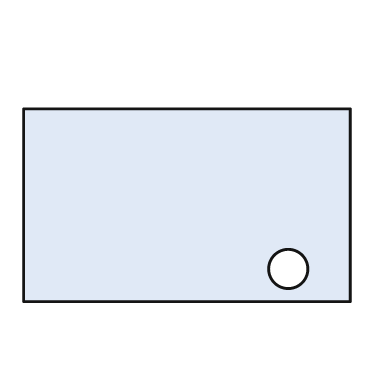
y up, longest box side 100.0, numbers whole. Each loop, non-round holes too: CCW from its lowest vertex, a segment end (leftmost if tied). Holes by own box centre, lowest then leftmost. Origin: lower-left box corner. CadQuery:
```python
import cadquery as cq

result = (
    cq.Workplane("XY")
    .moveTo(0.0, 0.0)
    .lineTo(100.0, 0.0)
    .lineTo(100.0, 59.0)
    .lineTo(0.0, 59.0)
    .close()
    .moveTo(81.0, 10.0)
    .circle(6.0)
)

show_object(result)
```